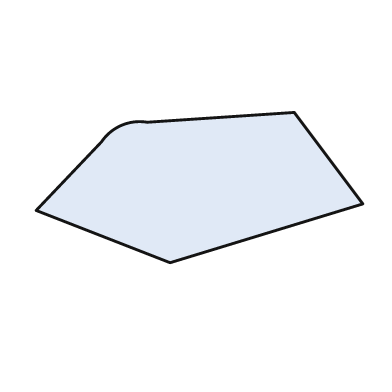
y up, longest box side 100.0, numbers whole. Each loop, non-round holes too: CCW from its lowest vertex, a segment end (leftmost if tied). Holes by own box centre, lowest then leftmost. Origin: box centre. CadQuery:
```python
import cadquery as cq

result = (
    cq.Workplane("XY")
    .moveTo(-9.0, -23.0)
    .lineTo(50.0, -5.0)
    .lineTo(29.0, 23.0)
    .lineTo(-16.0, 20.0)
    .threePointArc((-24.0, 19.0), (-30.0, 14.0))
    .lineTo(-50.0, -7.0)
    .close()
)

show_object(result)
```